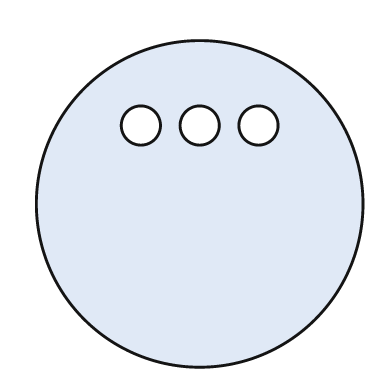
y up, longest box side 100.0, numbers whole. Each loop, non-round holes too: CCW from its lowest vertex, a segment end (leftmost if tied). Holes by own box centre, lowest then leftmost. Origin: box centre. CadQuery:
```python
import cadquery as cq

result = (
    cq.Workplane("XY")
    .moveTo(0.0, 0.0)
    .circle(50.0)
    .moveTo(-18.0, 24.0)
    .circle(6.0)
    .moveTo(0.0, 24.0)
    .circle(6.0)
    .moveTo(18.0, 24.0)
    .circle(6.0)
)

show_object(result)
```